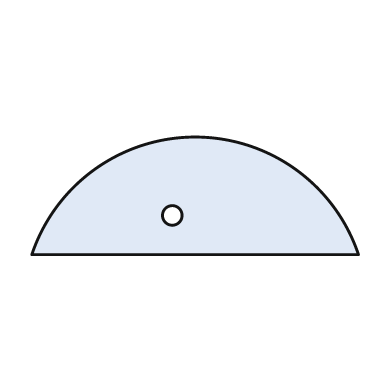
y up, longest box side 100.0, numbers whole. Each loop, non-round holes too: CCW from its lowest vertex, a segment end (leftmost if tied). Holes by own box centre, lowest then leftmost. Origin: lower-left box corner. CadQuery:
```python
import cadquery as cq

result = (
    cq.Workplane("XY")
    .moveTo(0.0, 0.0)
    .lineTo(100.0, 0.0)
    .threePointArc((50.0, 36.0), (0.0, 0.0))
    .close()
    .moveTo(43.0, 12.0)
    .circle(3.0)
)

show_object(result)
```